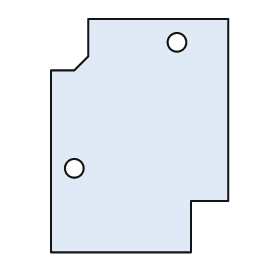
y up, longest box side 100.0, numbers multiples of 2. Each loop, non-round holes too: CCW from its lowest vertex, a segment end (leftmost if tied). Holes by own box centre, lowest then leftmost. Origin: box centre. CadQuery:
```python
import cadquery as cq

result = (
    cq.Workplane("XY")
    .moveTo(-38.0, -50.0)
    .lineTo(22.0, -50.0)
    .lineTo(22.0, -28.0)
    .lineTo(38.0, -28.0)
    .lineTo(38.0, 50.0)
    .lineTo(-22.0, 50.0)
    .lineTo(-22.0, 34.0)
    .lineTo(-28.0, 28.0)
    .lineTo(-38.0, 28.0)
    .close()
    .moveTo(-28.0, -14.0)
    .circle(4.0)
    .moveTo(16.0, 40.0)
    .circle(4.0)
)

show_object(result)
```